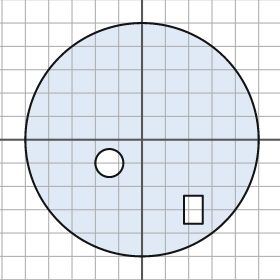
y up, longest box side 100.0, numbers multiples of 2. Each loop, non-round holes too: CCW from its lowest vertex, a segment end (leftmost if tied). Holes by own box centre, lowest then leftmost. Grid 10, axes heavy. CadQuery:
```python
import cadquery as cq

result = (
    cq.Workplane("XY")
    .moveTo(0.0, 0.0)
    .circle(50.0)
    .moveTo(18.0, -36.0)
    .lineTo(26.0, -36.0)
    .lineTo(26.0, -24.0)
    .lineTo(18.0, -24.0)
    .close()
    .moveTo(-14.0, -10.0)
    .circle(6.0)
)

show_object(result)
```